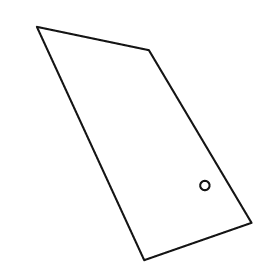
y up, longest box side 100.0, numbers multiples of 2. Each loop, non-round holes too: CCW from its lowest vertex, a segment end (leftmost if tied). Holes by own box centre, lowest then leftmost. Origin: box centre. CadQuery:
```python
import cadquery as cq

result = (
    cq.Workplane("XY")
    .moveTo(0.0, -50.0)
    .lineTo(46.0, -34.0)
    .lineTo(2.0, 40.0)
    .lineTo(-46.0, 50.0)
    .close()
    .moveTo(26.0, -18.0)
    .circle(2.0)
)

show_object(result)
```